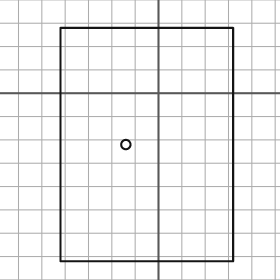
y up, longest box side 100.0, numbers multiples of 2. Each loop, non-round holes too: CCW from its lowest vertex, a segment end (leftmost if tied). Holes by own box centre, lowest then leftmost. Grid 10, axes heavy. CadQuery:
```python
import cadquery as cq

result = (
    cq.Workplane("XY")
    .moveTo(-42.0, -72.0)
    .lineTo(32.0, -72.0)
    .lineTo(32.0, 28.0)
    .lineTo(-42.0, 28.0)
    .close()
    .moveTo(-14.0, -22.0)
    .circle(2.0)
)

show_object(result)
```